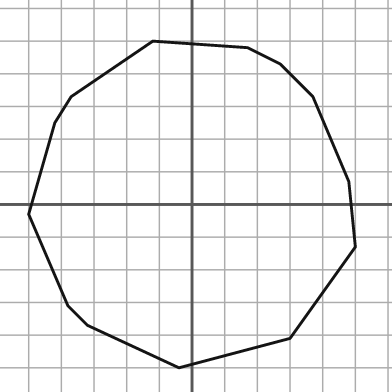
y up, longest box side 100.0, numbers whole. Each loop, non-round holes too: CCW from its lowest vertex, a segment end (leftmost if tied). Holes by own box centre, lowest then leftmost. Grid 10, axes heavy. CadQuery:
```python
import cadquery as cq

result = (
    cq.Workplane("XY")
    .moveTo(-4.0, -50.0)
    .lineTo(30.0, -41.0)
    .lineTo(50.0, -13.0)
    .lineTo(48.0, 7.0)
    .lineTo(37.0, 33.0)
    .lineTo(27.0, 43.0)
    .lineTo(17.0, 48.0)
    .lineTo(-12.0, 50.0)
    .lineTo(-37.0, 33.0)
    .lineTo(-42.0, 25.0)
    .lineTo(-50.0, -3.0)
    .lineTo(-38.0, -31.0)
    .lineTo(-32.0, -37.0)
    .close()
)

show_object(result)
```